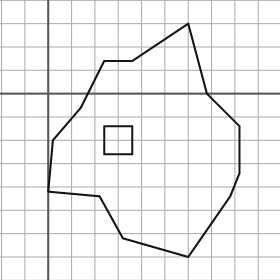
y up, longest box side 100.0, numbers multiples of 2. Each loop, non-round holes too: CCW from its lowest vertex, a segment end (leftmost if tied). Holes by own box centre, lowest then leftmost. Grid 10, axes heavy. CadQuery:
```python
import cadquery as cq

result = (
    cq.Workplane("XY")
    .moveTo(60.0, -70.0)
    .lineTo(78.0, -44.0)
    .lineTo(82.0, -34.0)
    .lineTo(82.0, -14.0)
    .lineTo(68.0, 0.0)
    .lineTo(60.0, 30.0)
    .lineTo(36.0, 14.0)
    .lineTo(24.0, 14.0)
    .lineTo(14.0, -6.0)
    .lineTo(2.0, -20.0)
    .lineTo(0.0, -42.0)
    .lineTo(22.0, -44.0)
    .lineTo(32.0, -62.0)
    .close()
    .moveTo(24.0, -26.0)
    .lineTo(36.0, -26.0)
    .lineTo(36.0, -14.0)
    .lineTo(24.0, -14.0)
    .close()
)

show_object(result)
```